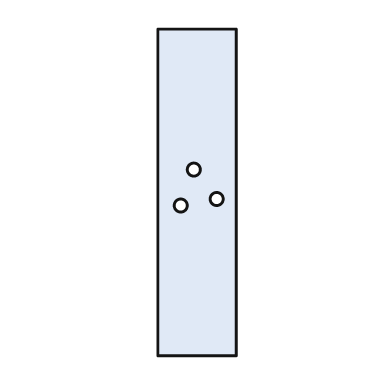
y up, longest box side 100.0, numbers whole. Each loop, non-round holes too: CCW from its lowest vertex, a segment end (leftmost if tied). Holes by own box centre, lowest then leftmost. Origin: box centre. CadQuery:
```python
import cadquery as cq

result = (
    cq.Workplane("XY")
    .moveTo(-12.0, -50.0)
    .lineTo(12.0, -50.0)
    .lineTo(12.0, 50.0)
    .lineTo(-12.0, 50.0)
    .close()
    .moveTo(-5.0, -4.0)
    .circle(2.0)
    .moveTo(6.0, -2.0)
    .circle(2.0)
    .moveTo(-1.0, 7.0)
    .circle(2.0)
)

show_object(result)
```